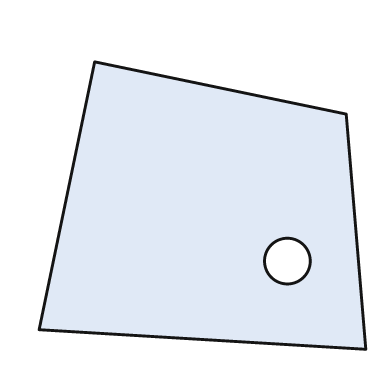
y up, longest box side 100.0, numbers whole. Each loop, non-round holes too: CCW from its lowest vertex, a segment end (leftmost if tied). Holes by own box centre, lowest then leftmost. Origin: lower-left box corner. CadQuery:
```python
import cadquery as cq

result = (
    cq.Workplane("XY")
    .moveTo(100.0, 0.0)
    .lineTo(94.0, 72.0)
    .lineTo(17.0, 88.0)
    .lineTo(0.0, 6.0)
    .close()
    .moveTo(76.0, 27.0)
    .circle(7.0)
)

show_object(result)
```